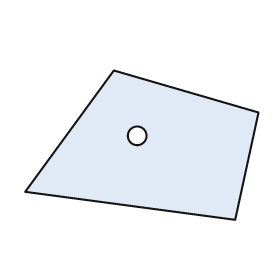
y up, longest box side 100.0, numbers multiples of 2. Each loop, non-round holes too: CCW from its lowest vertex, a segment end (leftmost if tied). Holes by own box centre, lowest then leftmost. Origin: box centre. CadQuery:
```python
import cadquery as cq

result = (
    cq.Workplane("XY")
    .moveTo(40.0, -32.0)
    .lineTo(50.0, 14.0)
    .lineTo(-12.0, 32.0)
    .lineTo(-50.0, -20.0)
    .close()
    .moveTo(-2.0, 4.0)
    .circle(4.0)
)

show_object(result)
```